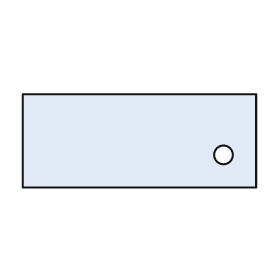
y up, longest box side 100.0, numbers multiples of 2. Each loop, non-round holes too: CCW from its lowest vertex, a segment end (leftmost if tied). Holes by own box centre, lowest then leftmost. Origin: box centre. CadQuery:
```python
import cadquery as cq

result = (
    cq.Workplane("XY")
    .moveTo(-50.0, -20.0)
    .lineTo(50.0, -20.0)
    .lineTo(50.0, 20.0)
    .lineTo(-50.0, 20.0)
    .close()
    .moveTo(36.0, -6.0)
    .circle(4.0)
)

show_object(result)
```